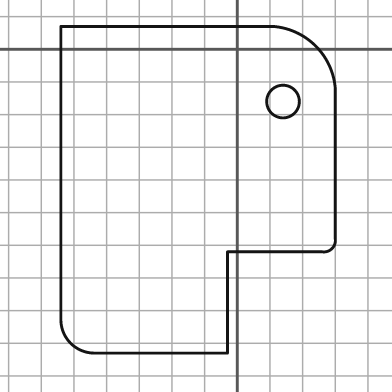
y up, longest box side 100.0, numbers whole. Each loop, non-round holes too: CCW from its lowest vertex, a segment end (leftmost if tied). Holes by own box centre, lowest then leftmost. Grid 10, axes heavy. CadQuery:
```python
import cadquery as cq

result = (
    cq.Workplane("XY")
    .moveTo(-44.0, -93.0)
    .lineTo(-3.0, -93.0)
    .lineTo(-3.0, -62.0)
    .lineTo(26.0, -62.0)
    .threePointArc((29.0, -61.0), (30.0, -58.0))
    .lineTo(30.0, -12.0)
    .threePointArc((24.0, 1.0), (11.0, 7.0))
    .lineTo(-54.0, 7.0)
    .lineTo(-54.0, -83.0)
    .threePointArc((-51.0, -90.0), (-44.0, -93.0))
    .close()
    .moveTo(14.0, -16.0)
    .circle(5.0)
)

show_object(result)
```